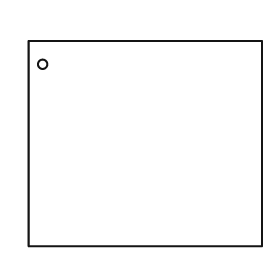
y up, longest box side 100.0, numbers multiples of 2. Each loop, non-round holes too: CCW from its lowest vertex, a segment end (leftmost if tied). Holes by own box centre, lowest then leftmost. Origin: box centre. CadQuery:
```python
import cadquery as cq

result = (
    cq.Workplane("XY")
    .moveTo(-50.0, -44.0)
    .lineTo(50.0, -44.0)
    .lineTo(50.0, 44.0)
    .lineTo(-50.0, 44.0)
    .close()
    .moveTo(-44.0, 34.0)
    .circle(2.0)
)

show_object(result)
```